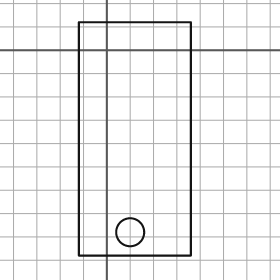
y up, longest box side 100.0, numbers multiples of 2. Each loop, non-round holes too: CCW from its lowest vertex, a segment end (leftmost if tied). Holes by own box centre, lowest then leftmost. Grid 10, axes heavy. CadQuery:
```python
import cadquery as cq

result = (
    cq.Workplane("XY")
    .moveTo(-12.0, -88.0)
    .lineTo(36.0, -88.0)
    .lineTo(36.0, 12.0)
    .lineTo(-12.0, 12.0)
    .close()
    .moveTo(10.0, -78.0)
    .circle(6.0)
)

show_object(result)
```